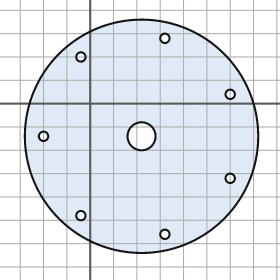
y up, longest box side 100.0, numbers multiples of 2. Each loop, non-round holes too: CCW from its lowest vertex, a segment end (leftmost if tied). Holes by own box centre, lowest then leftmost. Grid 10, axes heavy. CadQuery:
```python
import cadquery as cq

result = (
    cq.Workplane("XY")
    .moveTo(22.0, -14.0)
    .circle(50.0)
    .moveTo(32.0, -56.0)
    .circle(2.0)
    .moveTo(-4.0, -48.0)
    .circle(2.0)
    .moveTo(60.0, -32.0)
    .circle(2.0)
    .moveTo(-20.0, -14.0)
    .circle(2.0)
    .moveTo(22.0, -14.0)
    .circle(6.0)
    .moveTo(60.0, 4.0)
    .circle(2.0)
    .moveTo(-4.0, 20.0)
    .circle(2.0)
    .moveTo(32.0, 28.0)
    .circle(2.0)
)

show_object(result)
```